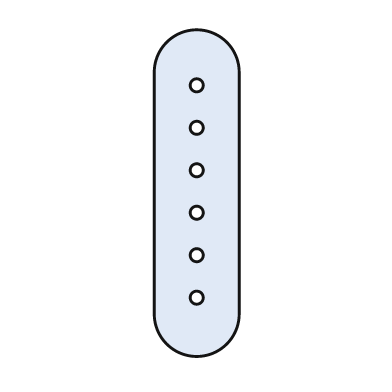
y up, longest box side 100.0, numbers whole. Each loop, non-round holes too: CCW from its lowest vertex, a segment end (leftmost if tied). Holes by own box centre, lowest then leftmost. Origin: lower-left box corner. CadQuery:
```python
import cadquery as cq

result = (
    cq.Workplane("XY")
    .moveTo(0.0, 13.0)
    .threePointArc((13.0, 0.0), (26.0, 13.0))
    .lineTo(26.0, 87.0)
    .threePointArc((13.0, 100.0), (0.0, 87.0))
    .close()
    .moveTo(13.0, 18.0)
    .circle(2.0)
    .moveTo(13.0, 31.0)
    .circle(2.0)
    .moveTo(13.0, 44.0)
    .circle(2.0)
    .moveTo(13.0, 57.0)
    .circle(2.0)
    .moveTo(13.0, 70.0)
    .circle(2.0)
    .moveTo(13.0, 83.0)
    .circle(2.0)
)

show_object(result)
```